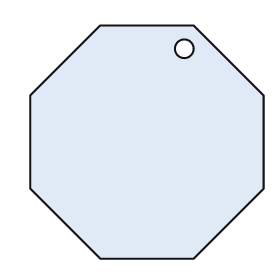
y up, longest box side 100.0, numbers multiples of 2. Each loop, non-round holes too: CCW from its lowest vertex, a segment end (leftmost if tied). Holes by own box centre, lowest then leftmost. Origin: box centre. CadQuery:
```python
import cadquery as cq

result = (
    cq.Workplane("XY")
    .moveTo(-20.0, -50.0)
    .lineTo(20.0, -50.0)
    .lineTo(50.0, -20.0)
    .lineTo(50.0, 20.0)
    .lineTo(20.0, 50.0)
    .lineTo(-20.0, 50.0)
    .lineTo(-50.0, 20.0)
    .lineTo(-50.0, -20.0)
    .close()
    .moveTo(16.0, 40.0)
    .circle(4.0)
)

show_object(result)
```